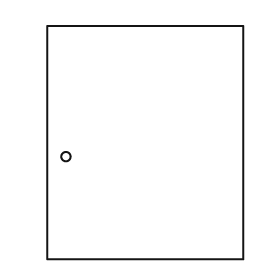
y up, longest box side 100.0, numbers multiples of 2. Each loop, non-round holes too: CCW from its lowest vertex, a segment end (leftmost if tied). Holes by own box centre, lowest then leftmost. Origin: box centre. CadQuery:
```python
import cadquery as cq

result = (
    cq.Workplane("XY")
    .moveTo(-42.0, -50.0)
    .lineTo(42.0, -50.0)
    .lineTo(42.0, 50.0)
    .lineTo(-42.0, 50.0)
    .close()
    .moveTo(-34.0, -6.0)
    .circle(2.0)
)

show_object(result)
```